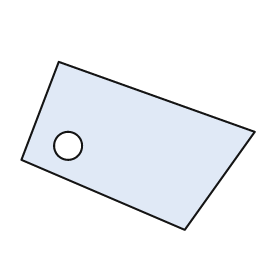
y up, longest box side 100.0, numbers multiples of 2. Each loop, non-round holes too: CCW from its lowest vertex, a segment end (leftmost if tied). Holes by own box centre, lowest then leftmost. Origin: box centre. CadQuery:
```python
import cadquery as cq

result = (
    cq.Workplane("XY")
    .moveTo(20.0, -36.0)
    .lineTo(50.0, 6.0)
    .lineTo(-34.0, 36.0)
    .lineTo(-50.0, -6.0)
    .close()
    .moveTo(-30.0, 0.0)
    .circle(6.0)
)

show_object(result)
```